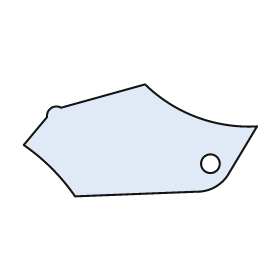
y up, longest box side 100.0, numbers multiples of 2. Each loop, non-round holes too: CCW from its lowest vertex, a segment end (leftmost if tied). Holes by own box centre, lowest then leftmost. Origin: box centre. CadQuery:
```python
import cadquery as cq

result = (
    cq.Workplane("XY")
    .moveTo(-28.0, -24.0)
    .lineTo(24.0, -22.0)
    .threePointArc((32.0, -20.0), (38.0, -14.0))
    .lineTo(50.0, 6.0)
    .threePointArc((24.0, 10.0), (2.0, 24.0))
    .lineTo(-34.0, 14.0)
    .threePointArc((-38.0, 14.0), (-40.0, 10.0))
    .lineTo(-50.0, -2.0)
    .threePointArc((-38.0, -12.0), (-28.0, -24.0))
    .close()
    .moveTo(30.0, -10.0)
    .circle(4.0)
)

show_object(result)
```